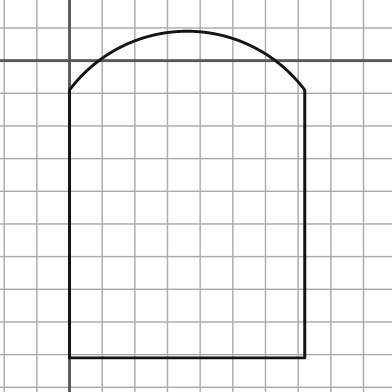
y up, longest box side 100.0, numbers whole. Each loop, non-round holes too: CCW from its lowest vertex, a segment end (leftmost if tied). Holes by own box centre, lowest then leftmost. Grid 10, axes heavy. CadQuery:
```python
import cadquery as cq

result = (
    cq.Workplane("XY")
    .moveTo(0.0, -91.0)
    .lineTo(72.0, -91.0)
    .lineTo(72.0, -9.0)
    .threePointArc((36.0, 9.0), (0.0, -9.0))
    .close()
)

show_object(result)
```